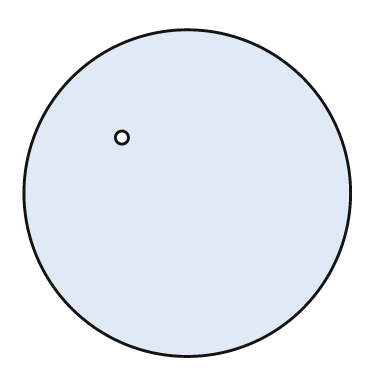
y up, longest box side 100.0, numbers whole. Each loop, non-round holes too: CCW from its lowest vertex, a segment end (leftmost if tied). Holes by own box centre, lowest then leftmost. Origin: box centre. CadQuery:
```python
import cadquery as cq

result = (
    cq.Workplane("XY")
    .moveTo(0.0, 0.0)
    .circle(50.0)
    .moveTo(-20.0, 17.0)
    .circle(2.0)
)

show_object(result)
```